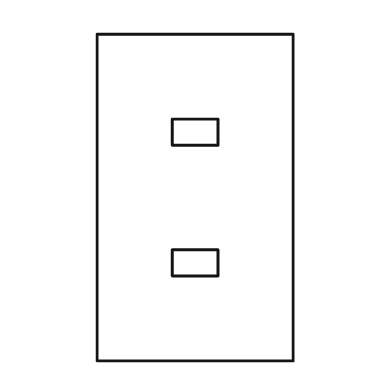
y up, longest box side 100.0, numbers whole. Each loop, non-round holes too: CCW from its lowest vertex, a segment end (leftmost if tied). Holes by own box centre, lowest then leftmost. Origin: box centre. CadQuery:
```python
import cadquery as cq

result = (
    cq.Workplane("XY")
    .moveTo(-30.0, -50.0)
    .lineTo(30.0, -50.0)
    .lineTo(30.0, 50.0)
    .lineTo(-30.0, 50.0)
    .close()
    .moveTo(-7.0, -24.0)
    .lineTo(7.0, -24.0)
    .lineTo(7.0, -16.0)
    .lineTo(-7.0, -16.0)
    .close()
    .moveTo(-7.0, 16.0)
    .lineTo(7.0, 16.0)
    .lineTo(7.0, 24.0)
    .lineTo(-7.0, 24.0)
    .close()
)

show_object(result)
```